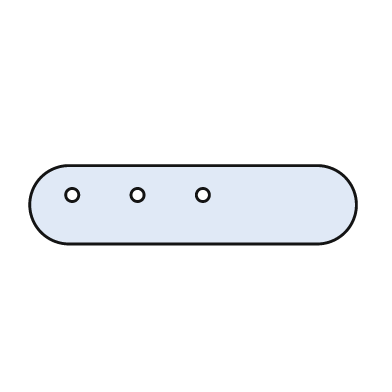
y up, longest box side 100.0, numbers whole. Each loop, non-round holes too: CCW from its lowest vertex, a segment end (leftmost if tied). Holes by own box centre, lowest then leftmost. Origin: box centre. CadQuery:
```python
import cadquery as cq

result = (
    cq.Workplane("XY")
    .moveTo(-38.0, -12.0)
    .lineTo(38.0, -12.0)
    .threePointArc((50.0, 0.0), (38.0, 12.0))
    .lineTo(-38.0, 12.0)
    .threePointArc((-50.0, 0.0), (-38.0, -12.0))
    .close()
    .moveTo(-37.0, 3.0)
    .circle(2.0)
    .moveTo(-17.0, 3.0)
    .circle(2.0)
    .moveTo(3.0, 3.0)
    .circle(2.0)
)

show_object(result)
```